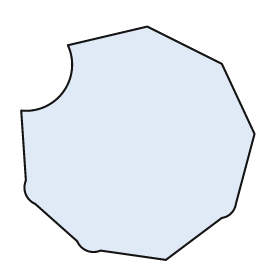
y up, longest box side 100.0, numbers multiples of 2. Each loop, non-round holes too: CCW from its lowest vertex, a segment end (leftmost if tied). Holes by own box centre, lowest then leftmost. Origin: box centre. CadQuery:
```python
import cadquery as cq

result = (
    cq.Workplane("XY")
    .moveTo(12.0, -50.0)
    .lineTo(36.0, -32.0)
    .threePointArc((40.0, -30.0), (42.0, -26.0))
    .lineTo(50.0, 4.0)
    .lineTo(36.0, 34.0)
    .lineTo(4.0, 50.0)
    .lineTo(-30.0, 42.0)
    .threePointArc((-32.0, 22.0), (-50.0, 14.0))
    .lineTo(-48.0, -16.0)
    .threePointArc((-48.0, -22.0), (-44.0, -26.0))
    .lineTo(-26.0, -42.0)
    .threePointArc((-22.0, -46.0), (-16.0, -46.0))
    .close()
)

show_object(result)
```